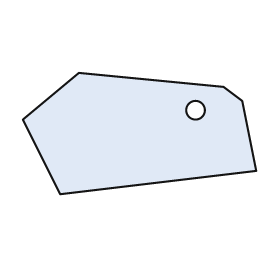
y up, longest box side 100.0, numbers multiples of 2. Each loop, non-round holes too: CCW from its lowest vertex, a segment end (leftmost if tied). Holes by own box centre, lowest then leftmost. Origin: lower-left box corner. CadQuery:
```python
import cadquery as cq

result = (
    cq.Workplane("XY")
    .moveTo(16.0, 0.0)
    .lineTo(100.0, 10.0)
    .lineTo(94.0, 40.0)
    .lineTo(86.0, 46.0)
    .lineTo(24.0, 52.0)
    .lineTo(0.0, 32.0)
    .close()
    .moveTo(74.0, 36.0)
    .circle(4.0)
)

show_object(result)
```